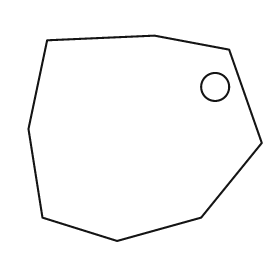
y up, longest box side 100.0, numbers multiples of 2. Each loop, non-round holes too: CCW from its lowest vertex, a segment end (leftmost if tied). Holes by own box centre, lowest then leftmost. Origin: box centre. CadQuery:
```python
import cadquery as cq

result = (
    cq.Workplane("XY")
    .moveTo(-12.0, -44.0)
    .lineTo(24.0, -34.0)
    .lineTo(50.0, -2.0)
    .lineTo(36.0, 38.0)
    .lineTo(4.0, 44.0)
    .lineTo(-42.0, 42.0)
    .lineTo(-50.0, 4.0)
    .lineTo(-44.0, -34.0)
    .close()
    .moveTo(30.0, 22.0)
    .circle(6.0)
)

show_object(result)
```